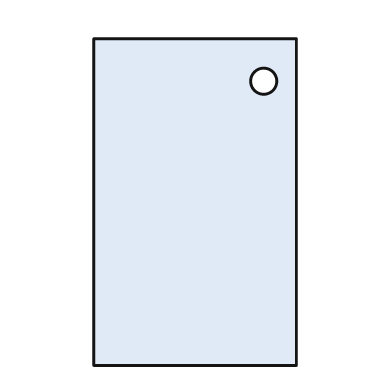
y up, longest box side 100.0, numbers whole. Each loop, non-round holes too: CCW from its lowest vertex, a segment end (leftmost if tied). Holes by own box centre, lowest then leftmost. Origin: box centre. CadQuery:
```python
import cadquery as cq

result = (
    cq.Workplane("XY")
    .moveTo(-31.0, -50.0)
    .lineTo(31.0, -50.0)
    .lineTo(31.0, 50.0)
    .lineTo(-31.0, 50.0)
    .close()
    .moveTo(21.0, 37.0)
    .circle(4.0)
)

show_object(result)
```